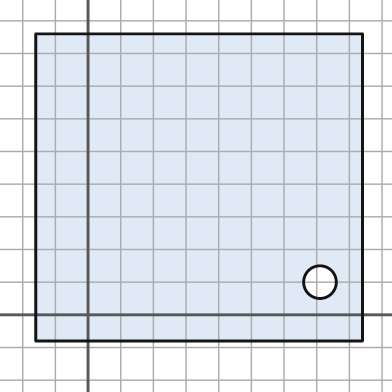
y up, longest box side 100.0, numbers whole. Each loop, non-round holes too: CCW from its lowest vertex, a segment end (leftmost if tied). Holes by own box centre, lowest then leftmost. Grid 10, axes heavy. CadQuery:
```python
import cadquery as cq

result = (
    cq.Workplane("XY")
    .moveTo(-16.0, -8.0)
    .lineTo(84.0, -8.0)
    .lineTo(84.0, 86.0)
    .lineTo(-16.0, 86.0)
    .close()
    .moveTo(71.0, 10.0)
    .circle(5.0)
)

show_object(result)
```